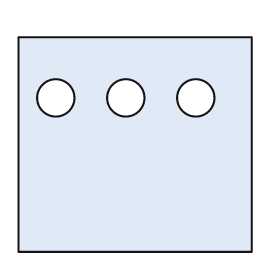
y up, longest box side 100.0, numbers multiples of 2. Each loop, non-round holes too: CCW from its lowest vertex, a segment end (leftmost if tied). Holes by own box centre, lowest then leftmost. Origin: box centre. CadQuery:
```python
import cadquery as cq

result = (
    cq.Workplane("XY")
    .moveTo(-50.0, -46.0)
    .lineTo(50.0, -46.0)
    .lineTo(50.0, 46.0)
    .lineTo(-50.0, 46.0)
    .close()
    .moveTo(-34.0, 20.0)
    .circle(8.0)
    .moveTo(-4.0, 20.0)
    .circle(8.0)
    .moveTo(26.0, 20.0)
    .circle(8.0)
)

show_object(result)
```